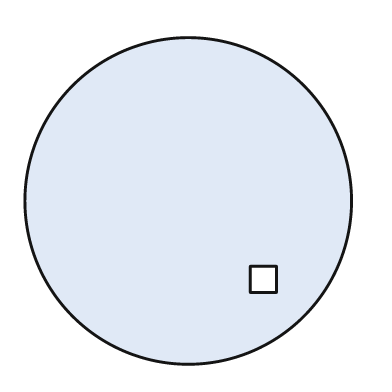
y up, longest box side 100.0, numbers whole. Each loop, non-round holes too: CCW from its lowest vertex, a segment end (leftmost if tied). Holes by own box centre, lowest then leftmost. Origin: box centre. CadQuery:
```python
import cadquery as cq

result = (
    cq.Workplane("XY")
    .moveTo(0.0, 0.0)
    .circle(50.0)
    .moveTo(19.0, -28.0)
    .lineTo(27.0, -28.0)
    .lineTo(27.0, -20.0)
    .lineTo(19.0, -20.0)
    .close()
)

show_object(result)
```